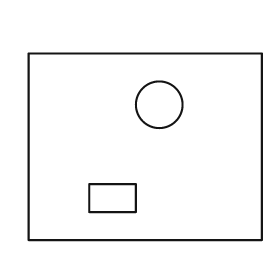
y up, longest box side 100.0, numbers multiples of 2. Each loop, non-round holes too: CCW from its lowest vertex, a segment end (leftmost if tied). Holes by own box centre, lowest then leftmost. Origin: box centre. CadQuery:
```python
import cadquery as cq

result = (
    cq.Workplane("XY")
    .moveTo(-50.0, -40.0)
    .lineTo(50.0, -40.0)
    .lineTo(50.0, 40.0)
    .lineTo(-50.0, 40.0)
    .close()
    .moveTo(-24.0, -28.0)
    .lineTo(-4.0, -28.0)
    .lineTo(-4.0, -16.0)
    .lineTo(-24.0, -16.0)
    .close()
    .moveTo(6.0, 18.0)
    .circle(10.0)
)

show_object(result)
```